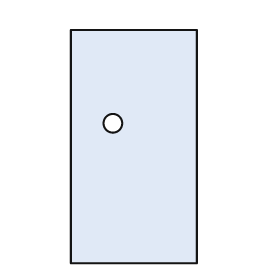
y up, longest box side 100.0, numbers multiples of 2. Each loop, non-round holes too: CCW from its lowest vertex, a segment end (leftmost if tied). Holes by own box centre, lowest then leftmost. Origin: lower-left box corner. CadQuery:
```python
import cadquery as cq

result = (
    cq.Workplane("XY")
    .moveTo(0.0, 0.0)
    .lineTo(54.0, 0.0)
    .lineTo(54.0, 100.0)
    .lineTo(0.0, 100.0)
    .close()
    .moveTo(18.0, 60.0)
    .circle(4.0)
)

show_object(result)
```